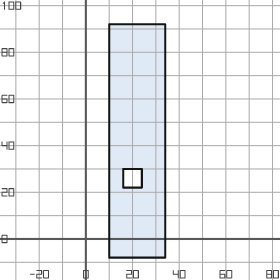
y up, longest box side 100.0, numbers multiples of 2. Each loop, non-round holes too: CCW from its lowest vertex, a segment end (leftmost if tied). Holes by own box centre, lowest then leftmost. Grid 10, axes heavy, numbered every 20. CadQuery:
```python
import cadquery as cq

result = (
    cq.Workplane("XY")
    .moveTo(10.0, -8.0)
    .lineTo(34.0, -8.0)
    .lineTo(34.0, 92.0)
    .lineTo(10.0, 92.0)
    .close()
    .moveTo(16.0, 22.0)
    .lineTo(24.0, 22.0)
    .lineTo(24.0, 30.0)
    .lineTo(16.0, 30.0)
    .close()
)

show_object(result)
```